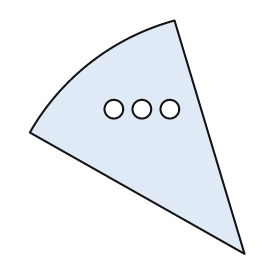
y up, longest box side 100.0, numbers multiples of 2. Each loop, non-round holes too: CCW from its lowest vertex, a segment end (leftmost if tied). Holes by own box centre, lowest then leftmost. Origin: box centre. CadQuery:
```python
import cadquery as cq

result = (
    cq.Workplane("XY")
    .moveTo(46.0, -50.0)
    .lineTo(16.0, 50.0)
    .threePointArc((-20.0, 32.0), (-46.0, 2.0))
    .close()
    .moveTo(-10.0, 12.0)
    .circle(4.0)
    .moveTo(2.0, 12.0)
    .circle(4.0)
    .moveTo(14.0, 12.0)
    .circle(4.0)
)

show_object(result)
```